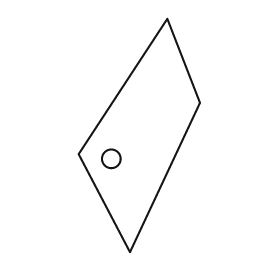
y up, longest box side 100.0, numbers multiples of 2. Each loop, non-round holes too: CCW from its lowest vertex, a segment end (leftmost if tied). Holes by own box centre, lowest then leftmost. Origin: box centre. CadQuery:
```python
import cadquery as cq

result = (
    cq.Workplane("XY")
    .moveTo(-4.0, -50.0)
    .lineTo(26.0, 14.0)
    .lineTo(12.0, 50.0)
    .lineTo(-26.0, -8.0)
    .close()
    .moveTo(-12.0, -10.0)
    .circle(4.0)
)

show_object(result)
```